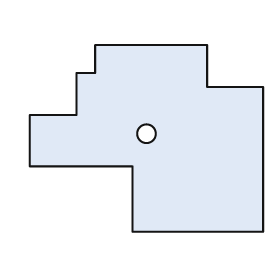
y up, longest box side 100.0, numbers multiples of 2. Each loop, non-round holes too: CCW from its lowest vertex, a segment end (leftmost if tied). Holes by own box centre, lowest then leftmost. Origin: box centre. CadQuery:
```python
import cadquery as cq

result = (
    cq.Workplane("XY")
    .moveTo(-6.0, -40.0)
    .lineTo(50.0, -40.0)
    .lineTo(50.0, 22.0)
    .lineTo(26.0, 22.0)
    .lineTo(26.0, 40.0)
    .lineTo(-22.0, 40.0)
    .lineTo(-22.0, 28.0)
    .lineTo(-30.0, 28.0)
    .lineTo(-30.0, 10.0)
    .lineTo(-50.0, 10.0)
    .lineTo(-50.0, -12.0)
    .lineTo(-6.0, -12.0)
    .close()
    .moveTo(0.0, 2.0)
    .circle(4.0)
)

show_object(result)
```